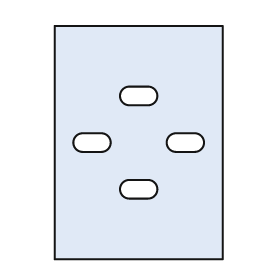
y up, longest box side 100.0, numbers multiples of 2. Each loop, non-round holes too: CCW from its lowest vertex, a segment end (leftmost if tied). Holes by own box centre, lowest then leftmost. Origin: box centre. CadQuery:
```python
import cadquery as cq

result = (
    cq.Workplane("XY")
    .moveTo(-36.0, -50.0)
    .lineTo(36.0, -50.0)
    .lineTo(36.0, 50.0)
    .lineTo(-36.0, 50.0)
    .close()
    .moveTo(-4.0, -24.0)
    .lineTo(4.0, -24.0)
    .threePointArc((8.0, -20.0), (4.0, -16.0))
    .lineTo(-4.0, -16.0)
    .threePointArc((-8.0, -20.0), (-4.0, -24.0))
    .close()
    .moveTo(-24.0, -4.0)
    .lineTo(-16.0, -4.0)
    .threePointArc((-12.0, 0.0), (-16.0, 4.0))
    .lineTo(-24.0, 4.0)
    .threePointArc((-28.0, 0.0), (-24.0, -4.0))
    .close()
    .moveTo(16.0, -4.0)
    .lineTo(24.0, -4.0)
    .threePointArc((28.0, 0.0), (24.0, 4.0))
    .lineTo(16.0, 4.0)
    .threePointArc((12.0, 0.0), (16.0, -4.0))
    .close()
    .moveTo(-4.0, 16.0)
    .lineTo(4.0, 16.0)
    .threePointArc((8.0, 20.0), (4.0, 24.0))
    .lineTo(-4.0, 24.0)
    .threePointArc((-8.0, 20.0), (-4.0, 16.0))
    .close()
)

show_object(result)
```